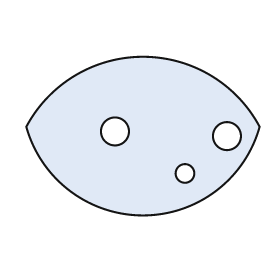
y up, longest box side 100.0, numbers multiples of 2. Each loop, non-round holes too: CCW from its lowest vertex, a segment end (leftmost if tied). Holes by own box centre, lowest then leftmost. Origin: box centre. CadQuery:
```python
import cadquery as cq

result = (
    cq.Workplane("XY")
    .moveTo(-50.0, 4.0)
    .threePointArc((0.0, -34.0), (50.0, 4.0))
    .threePointArc((0.0, 34.0), (-50.0, 4.0))
    .close()
    .moveTo(18.0, -16.0)
    .circle(4.0)
    .moveTo(36.0, 0.0)
    .circle(6.0)
    .moveTo(-12.0, 2.0)
    .circle(6.0)
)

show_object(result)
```